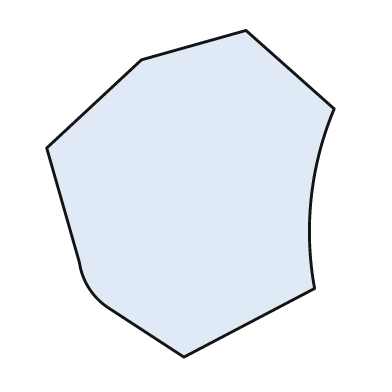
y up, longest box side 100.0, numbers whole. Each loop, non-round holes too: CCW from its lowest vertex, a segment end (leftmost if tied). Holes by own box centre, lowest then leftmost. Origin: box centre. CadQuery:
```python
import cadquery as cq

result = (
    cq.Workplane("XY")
    .moveTo(-2.0, -50.0)
    .lineTo(38.0, -29.0)
    .threePointArc((37.0, -1.0), (44.0, 26.0))
    .lineTo(17.0, 50.0)
    .lineTo(-15.0, 41.0)
    .lineTo(-44.0, 14.0)
    .lineTo(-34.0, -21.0)
    .threePointArc((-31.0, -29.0), (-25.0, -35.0))
    .close()
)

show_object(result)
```